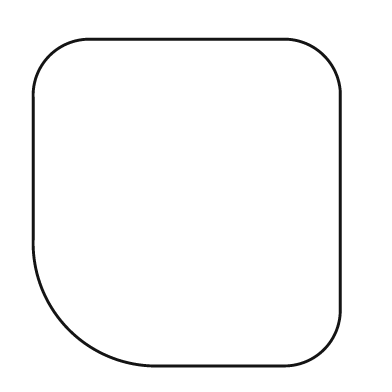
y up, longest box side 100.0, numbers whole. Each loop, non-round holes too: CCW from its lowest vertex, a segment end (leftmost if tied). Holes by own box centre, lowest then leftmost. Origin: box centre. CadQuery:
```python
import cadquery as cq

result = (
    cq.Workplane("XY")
    .moveTo(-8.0, -50.0)
    .lineTo(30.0, -50.0)
    .threePointArc((42.0, -45.0), (47.0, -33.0))
    .lineTo(47.0, 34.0)
    .threePointArc((42.0, 45.0), (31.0, 50.0))
    .lineTo(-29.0, 50.0)
    .threePointArc((-42.0, 45.0), (-47.0, 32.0))
    .lineTo(-47.0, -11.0)
    .threePointArc((-36.0, -39.0), (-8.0, -50.0))
    .close()
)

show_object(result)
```